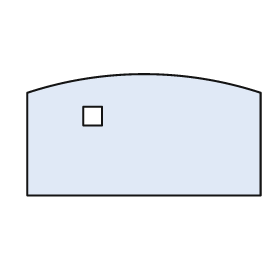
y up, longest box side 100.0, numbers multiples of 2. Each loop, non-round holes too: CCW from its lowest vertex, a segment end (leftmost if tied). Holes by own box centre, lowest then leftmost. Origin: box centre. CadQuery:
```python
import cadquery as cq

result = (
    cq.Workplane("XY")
    .moveTo(-50.0, -26.0)
    .lineTo(50.0, -26.0)
    .lineTo(50.0, 18.0)
    .threePointArc((0.0, 26.0), (-50.0, 18.0))
    .close()
    .moveTo(-26.0, 4.0)
    .lineTo(-18.0, 4.0)
    .lineTo(-18.0, 12.0)
    .lineTo(-26.0, 12.0)
    .close()
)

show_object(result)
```